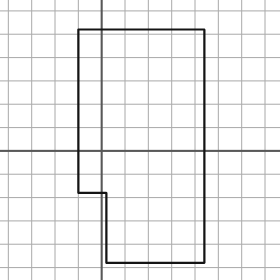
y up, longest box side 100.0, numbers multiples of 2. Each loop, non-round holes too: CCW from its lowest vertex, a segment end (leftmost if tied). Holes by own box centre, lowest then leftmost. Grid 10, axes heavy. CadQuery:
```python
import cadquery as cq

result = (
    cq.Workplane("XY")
    .moveTo(2.0, -48.0)
    .lineTo(44.0, -48.0)
    .lineTo(44.0, 52.0)
    .lineTo(-10.0, 52.0)
    .lineTo(-10.0, -18.0)
    .lineTo(2.0, -18.0)
    .close()
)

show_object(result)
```